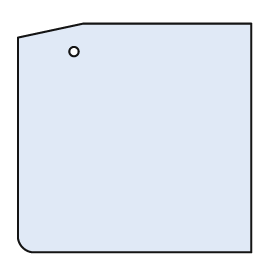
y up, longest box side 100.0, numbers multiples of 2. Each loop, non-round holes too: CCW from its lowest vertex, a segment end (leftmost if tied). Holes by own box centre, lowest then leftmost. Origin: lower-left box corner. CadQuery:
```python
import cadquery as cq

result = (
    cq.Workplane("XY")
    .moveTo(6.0, 0.0)
    .lineTo(100.0, 0.0)
    .lineTo(100.0, 98.0)
    .lineTo(28.0, 98.0)
    .lineTo(0.0, 92.0)
    .lineTo(0.0, 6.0)
    .threePointArc((2.0, 2.0), (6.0, 0.0))
    .close()
    .moveTo(24.0, 86.0)
    .circle(2.0)
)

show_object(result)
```